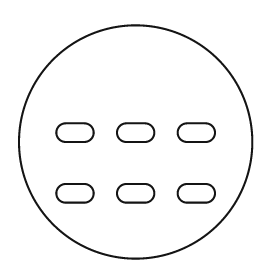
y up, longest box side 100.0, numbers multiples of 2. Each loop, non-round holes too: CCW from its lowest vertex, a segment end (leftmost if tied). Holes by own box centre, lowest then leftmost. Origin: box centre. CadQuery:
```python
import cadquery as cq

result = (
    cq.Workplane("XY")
    .moveTo(0.0, 0.0)
    .circle(50.0)
    .moveTo(-30.0, -26.0)
    .lineTo(-22.0, -26.0)
    .threePointArc((-18.0, -22.0), (-22.0, -18.0))
    .lineTo(-30.0, -18.0)
    .threePointArc((-34.0, -22.0), (-30.0, -26.0))
    .close()
    .moveTo(-4.0, -26.0)
    .lineTo(4.0, -26.0)
    .threePointArc((8.0, -22.0), (4.0, -18.0))
    .lineTo(-4.0, -18.0)
    .threePointArc((-8.0, -22.0), (-4.0, -26.0))
    .close()
    .moveTo(22.0, -26.0)
    .lineTo(30.0, -26.0)
    .threePointArc((34.0, -22.0), (30.0, -18.0))
    .lineTo(22.0, -18.0)
    .threePointArc((18.0, -22.0), (22.0, -26.0))
    .close()
    .moveTo(-30.0, 0.0)
    .lineTo(-22.0, 0.0)
    .threePointArc((-18.0, 4.0), (-22.0, 8.0))
    .lineTo(-30.0, 8.0)
    .threePointArc((-34.0, 4.0), (-30.0, 0.0))
    .close()
    .moveTo(-4.0, 0.0)
    .lineTo(4.0, 0.0)
    .threePointArc((8.0, 4.0), (4.0, 8.0))
    .lineTo(-4.0, 8.0)
    .threePointArc((-8.0, 4.0), (-4.0, 0.0))
    .close()
    .moveTo(22.0, 0.0)
    .lineTo(30.0, 0.0)
    .threePointArc((34.0, 4.0), (30.0, 8.0))
    .lineTo(22.0, 8.0)
    .threePointArc((18.0, 4.0), (22.0, 0.0))
    .close()
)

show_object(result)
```